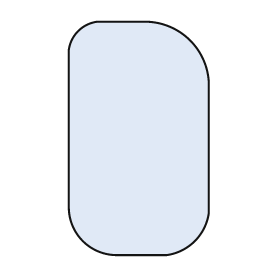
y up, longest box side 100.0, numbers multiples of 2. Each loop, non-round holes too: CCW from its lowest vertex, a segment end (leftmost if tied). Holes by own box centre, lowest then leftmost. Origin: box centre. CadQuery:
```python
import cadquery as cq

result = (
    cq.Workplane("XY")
    .moveTo(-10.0, -50.0)
    .lineTo(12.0, -50.0)
    .threePointArc((24.0, -44.0), (30.0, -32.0))
    .lineTo(30.0, 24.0)
    .threePointArc((22.0, 42.0), (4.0, 50.0))
    .lineTo(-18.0, 50.0)
    .threePointArc((-26.0, 46.0), (-30.0, 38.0))
    .lineTo(-30.0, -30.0)
    .threePointArc((-24.0, -44.0), (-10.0, -50.0))
    .close()
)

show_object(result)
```